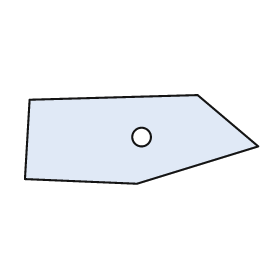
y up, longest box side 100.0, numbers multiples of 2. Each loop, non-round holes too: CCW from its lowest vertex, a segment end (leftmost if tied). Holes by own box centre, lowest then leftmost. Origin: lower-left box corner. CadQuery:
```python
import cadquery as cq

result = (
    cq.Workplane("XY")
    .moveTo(48.0, 0.0)
    .lineTo(100.0, 16.0)
    .lineTo(74.0, 38.0)
    .lineTo(2.0, 36.0)
    .lineTo(0.0, 2.0)
    .close()
    .moveTo(50.0, 20.0)
    .circle(4.0)
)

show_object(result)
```